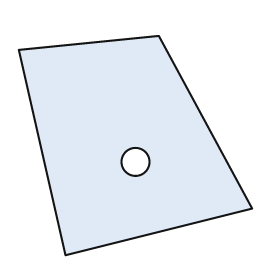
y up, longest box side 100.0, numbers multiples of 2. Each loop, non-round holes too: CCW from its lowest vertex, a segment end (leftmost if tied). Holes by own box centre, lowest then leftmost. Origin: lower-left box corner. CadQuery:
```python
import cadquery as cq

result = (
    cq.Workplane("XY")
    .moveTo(20.0, 0.0)
    .lineTo(100.0, 20.0)
    .lineTo(60.0, 94.0)
    .lineTo(0.0, 88.0)
    .close()
    .moveTo(50.0, 40.0)
    .circle(6.0)
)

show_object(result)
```